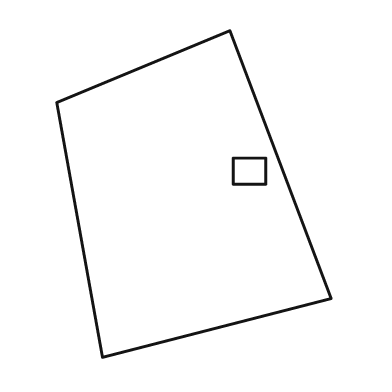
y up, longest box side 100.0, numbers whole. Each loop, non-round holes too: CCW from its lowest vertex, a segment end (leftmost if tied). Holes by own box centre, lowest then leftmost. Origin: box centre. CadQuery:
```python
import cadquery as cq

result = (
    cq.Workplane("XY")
    .moveTo(-28.0, -50.0)
    .lineTo(42.0, -32.0)
    .lineTo(11.0, 50.0)
    .lineTo(-42.0, 28.0)
    .close()
    .moveTo(12.0, 3.0)
    .lineTo(22.0, 3.0)
    .lineTo(22.0, 11.0)
    .lineTo(12.0, 11.0)
    .close()
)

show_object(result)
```